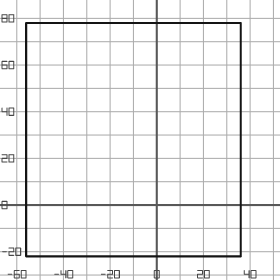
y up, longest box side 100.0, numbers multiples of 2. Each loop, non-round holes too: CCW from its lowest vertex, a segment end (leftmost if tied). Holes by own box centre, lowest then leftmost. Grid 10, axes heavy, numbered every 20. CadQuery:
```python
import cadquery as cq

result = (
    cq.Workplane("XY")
    .moveTo(-56.0, -22.0)
    .lineTo(36.0, -22.0)
    .lineTo(36.0, 78.0)
    .lineTo(-56.0, 78.0)
    .close()
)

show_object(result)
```